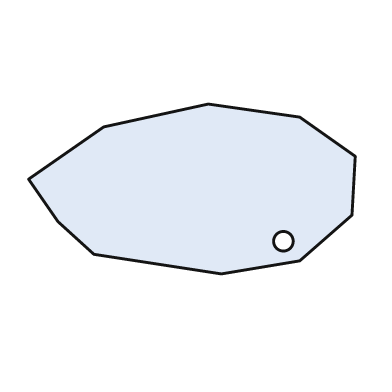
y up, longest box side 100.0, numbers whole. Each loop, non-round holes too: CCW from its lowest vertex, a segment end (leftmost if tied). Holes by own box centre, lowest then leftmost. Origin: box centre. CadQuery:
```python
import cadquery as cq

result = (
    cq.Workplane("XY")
    .moveTo(9.0, -26.0)
    .lineTo(33.0, -22.0)
    .lineTo(49.0, -8.0)
    .lineTo(50.0, 10.0)
    .lineTo(33.0, 22.0)
    .lineTo(5.0, 26.0)
    .lineTo(-27.0, 19.0)
    .lineTo(-50.0, 3.0)
    .lineTo(-41.0, -10.0)
    .lineTo(-30.0, -20.0)
    .close()
    .moveTo(28.0, -16.0)
    .circle(3.0)
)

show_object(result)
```